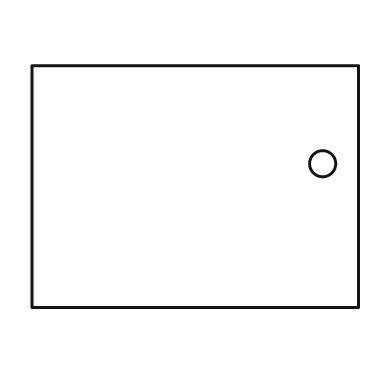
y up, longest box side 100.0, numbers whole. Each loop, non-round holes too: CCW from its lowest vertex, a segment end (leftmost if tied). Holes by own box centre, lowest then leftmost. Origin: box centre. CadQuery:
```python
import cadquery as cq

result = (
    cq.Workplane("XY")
    .moveTo(-50.0, -37.0)
    .lineTo(50.0, -37.0)
    .lineTo(50.0, 37.0)
    .lineTo(-50.0, 37.0)
    .close()
    .moveTo(39.0, 7.0)
    .circle(4.0)
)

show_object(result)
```